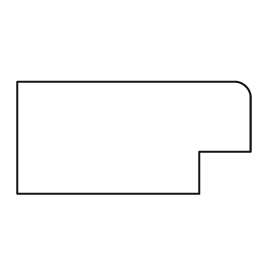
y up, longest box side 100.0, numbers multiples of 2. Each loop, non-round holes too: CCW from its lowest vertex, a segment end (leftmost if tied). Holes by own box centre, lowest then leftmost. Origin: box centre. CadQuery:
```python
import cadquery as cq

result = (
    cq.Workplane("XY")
    .moveTo(-50.0, -24.0)
    .lineTo(28.0, -24.0)
    .lineTo(28.0, -6.0)
    .lineTo(50.0, -6.0)
    .lineTo(50.0, 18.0)
    .threePointArc((48.0, 22.0), (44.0, 24.0))
    .lineTo(-50.0, 24.0)
    .close()
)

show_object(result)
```